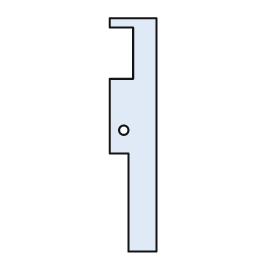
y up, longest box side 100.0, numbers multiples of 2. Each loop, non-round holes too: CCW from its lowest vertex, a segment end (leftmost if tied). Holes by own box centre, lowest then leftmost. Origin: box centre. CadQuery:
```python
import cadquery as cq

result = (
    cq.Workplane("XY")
    .moveTo(-2.0, -50.0)
    .lineTo(10.0, -50.0)
    .lineTo(10.0, 50.0)
    .lineTo(-10.0, 50.0)
    .lineTo(-10.0, 46.0)
    .lineTo(0.0, 46.0)
    .lineTo(0.0, 24.0)
    .lineTo(-10.0, 24.0)
    .lineTo(-10.0, -8.0)
    .lineTo(-2.0, -8.0)
    .close()
    .moveTo(-4.0, 2.0)
    .circle(2.0)
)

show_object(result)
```